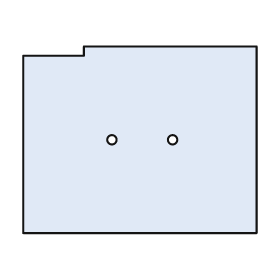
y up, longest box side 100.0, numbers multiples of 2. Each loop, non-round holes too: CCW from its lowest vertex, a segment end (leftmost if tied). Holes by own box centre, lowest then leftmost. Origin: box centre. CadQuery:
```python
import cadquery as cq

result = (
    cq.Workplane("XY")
    .moveTo(-50.0, -40.0)
    .lineTo(50.0, -40.0)
    .lineTo(50.0, 40.0)
    .lineTo(-24.0, 40.0)
    .lineTo(-24.0, 36.0)
    .lineTo(-50.0, 36.0)
    .close()
    .moveTo(-12.0, 0.0)
    .circle(2.0)
    .moveTo(14.0, 0.0)
    .circle(2.0)
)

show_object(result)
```